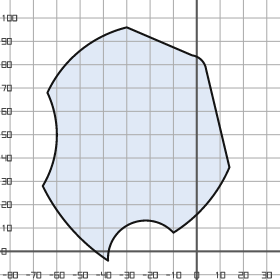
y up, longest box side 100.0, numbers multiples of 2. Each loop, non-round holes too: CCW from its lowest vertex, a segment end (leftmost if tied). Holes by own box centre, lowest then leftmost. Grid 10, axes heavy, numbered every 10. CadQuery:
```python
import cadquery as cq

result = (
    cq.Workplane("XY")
    .moveTo(-38.0, -4.0)
    .threePointArc((-28.0, 12.0), (-10.0, 8.0))
    .threePointArc((4.0, 20.0), (14.0, 36.0))
    .lineTo(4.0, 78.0)
    .threePointArc((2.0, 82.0), (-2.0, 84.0))
    .lineTo(-30.0, 96.0)
    .threePointArc((-50.0, 86.0), (-64.0, 68.0))
    .threePointArc((-60.0, 48.0), (-66.0, 28.0))
    .threePointArc((-54.0, 10.0), (-38.0, -4.0))
    .close()
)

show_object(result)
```